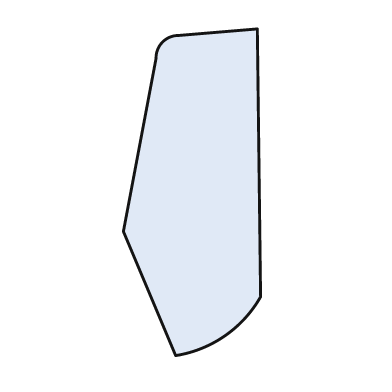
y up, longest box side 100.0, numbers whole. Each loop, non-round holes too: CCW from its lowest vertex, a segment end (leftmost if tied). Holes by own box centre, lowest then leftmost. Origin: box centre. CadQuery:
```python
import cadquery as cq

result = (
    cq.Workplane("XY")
    .moveTo(-5.0, -50.0)
    .threePointArc((10.0, -44.0), (21.0, -32.0))
    .lineTo(20.0, 50.0)
    .lineTo(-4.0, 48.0)
    .threePointArc((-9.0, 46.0), (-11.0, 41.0))
    .lineTo(-21.0, -12.0)
    .close()
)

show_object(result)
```